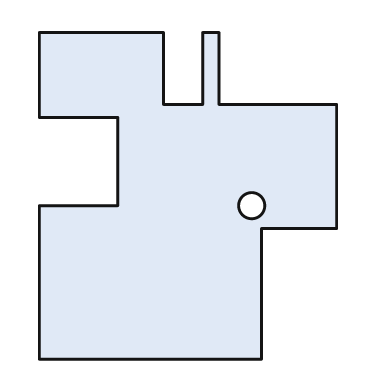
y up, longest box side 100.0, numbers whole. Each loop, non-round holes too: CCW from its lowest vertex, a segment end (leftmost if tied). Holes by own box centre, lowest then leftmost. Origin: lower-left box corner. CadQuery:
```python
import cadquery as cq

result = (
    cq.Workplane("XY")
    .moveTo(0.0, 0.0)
    .lineTo(68.0, 0.0)
    .lineTo(68.0, 40.0)
    .lineTo(91.0, 40.0)
    .lineTo(91.0, 78.0)
    .lineTo(55.0, 78.0)
    .lineTo(55.0, 100.0)
    .lineTo(50.0, 100.0)
    .lineTo(50.0, 78.0)
    .lineTo(38.0, 78.0)
    .lineTo(38.0, 100.0)
    .lineTo(0.0, 100.0)
    .lineTo(0.0, 74.0)
    .lineTo(24.0, 74.0)
    .lineTo(24.0, 47.0)
    .lineTo(0.0, 47.0)
    .close()
    .moveTo(65.0, 47.0)
    .circle(4.0)
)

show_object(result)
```